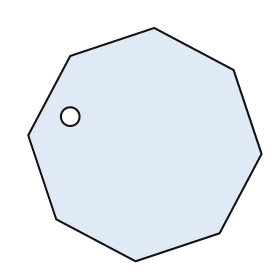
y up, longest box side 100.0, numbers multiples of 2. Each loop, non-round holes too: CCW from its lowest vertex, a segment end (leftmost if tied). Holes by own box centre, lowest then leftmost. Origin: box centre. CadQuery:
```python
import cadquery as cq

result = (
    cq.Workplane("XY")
    .moveTo(-4.0, -50.0)
    .lineTo(32.0, -38.0)
    .lineTo(50.0, -4.0)
    .lineTo(38.0, 32.0)
    .lineTo(4.0, 50.0)
    .lineTo(-32.0, 38.0)
    .lineTo(-50.0, 4.0)
    .lineTo(-38.0, -32.0)
    .close()
    .moveTo(-32.0, 12.0)
    .circle(4.0)
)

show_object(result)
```